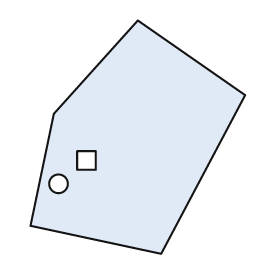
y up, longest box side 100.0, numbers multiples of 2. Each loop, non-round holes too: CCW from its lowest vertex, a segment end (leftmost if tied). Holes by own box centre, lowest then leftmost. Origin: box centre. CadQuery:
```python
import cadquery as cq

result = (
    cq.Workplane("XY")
    .moveTo(10.0, -50.0)
    .lineTo(46.0, 18.0)
    .lineTo(0.0, 50.0)
    .lineTo(-36.0, 10.0)
    .lineTo(-46.0, -38.0)
    .close()
    .moveTo(-34.0, -20.0)
    .circle(4.0)
    .moveTo(-26.0, -14.0)
    .lineTo(-18.0, -14.0)
    .lineTo(-18.0, -6.0)
    .lineTo(-26.0, -6.0)
    .close()
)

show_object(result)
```